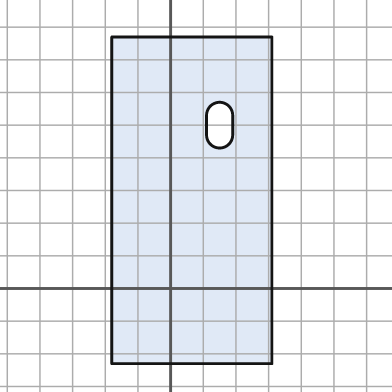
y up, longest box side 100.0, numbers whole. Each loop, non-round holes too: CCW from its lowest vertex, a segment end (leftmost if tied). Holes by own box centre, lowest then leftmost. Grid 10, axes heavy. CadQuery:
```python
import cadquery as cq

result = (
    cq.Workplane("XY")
    .moveTo(-18.0, -23.0)
    .lineTo(31.0, -23.0)
    .lineTo(31.0, 77.0)
    .lineTo(-18.0, 77.0)
    .close()
    .moveTo(11.0, 47.0)
    .threePointArc((15.0, 43.0), (19.0, 47.0))
    .lineTo(19.0, 53.0)
    .threePointArc((15.0, 57.0), (11.0, 53.0))
    .close()
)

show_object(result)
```